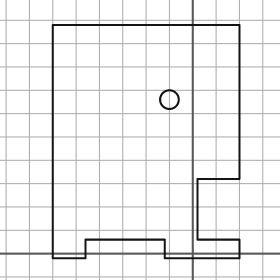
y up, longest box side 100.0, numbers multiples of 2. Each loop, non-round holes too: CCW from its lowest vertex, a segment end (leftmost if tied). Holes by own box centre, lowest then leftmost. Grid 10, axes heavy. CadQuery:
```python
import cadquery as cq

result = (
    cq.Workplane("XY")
    .moveTo(-60.0, -2.0)
    .lineTo(-46.0, -2.0)
    .lineTo(-46.0, 6.0)
    .lineTo(-12.0, 6.0)
    .lineTo(-12.0, -2.0)
    .lineTo(20.0, -2.0)
    .lineTo(20.0, 6.0)
    .lineTo(2.0, 6.0)
    .lineTo(2.0, 32.0)
    .lineTo(20.0, 32.0)
    .lineTo(20.0, 98.0)
    .lineTo(-60.0, 98.0)
    .close()
    .moveTo(-10.0, 66.0)
    .circle(4.0)
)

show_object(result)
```